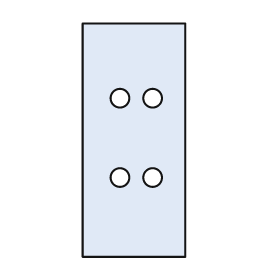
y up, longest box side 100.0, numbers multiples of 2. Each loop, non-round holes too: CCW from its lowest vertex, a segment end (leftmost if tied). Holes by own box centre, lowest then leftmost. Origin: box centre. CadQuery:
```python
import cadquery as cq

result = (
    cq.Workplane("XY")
    .moveTo(-22.0, -50.0)
    .lineTo(22.0, -50.0)
    .lineTo(22.0, 50.0)
    .lineTo(-22.0, 50.0)
    .close()
    .moveTo(-6.0, -16.0)
    .circle(4.0)
    .moveTo(8.0, -16.0)
    .circle(4.0)
    .moveTo(-6.0, 18.0)
    .circle(4.0)
    .moveTo(8.0, 18.0)
    .circle(4.0)
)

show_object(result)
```